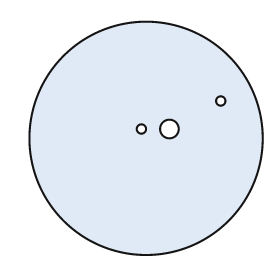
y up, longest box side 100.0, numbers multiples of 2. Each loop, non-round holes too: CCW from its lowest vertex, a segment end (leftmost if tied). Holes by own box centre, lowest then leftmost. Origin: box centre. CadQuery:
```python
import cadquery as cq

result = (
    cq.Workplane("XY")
    .moveTo(0.0, 0.0)
    .circle(50.0)
    .moveTo(-2.0, 4.0)
    .circle(2.0)
    .moveTo(10.0, 4.0)
    .circle(4.0)
    .moveTo(32.0, 16.0)
    .circle(2.0)
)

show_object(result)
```